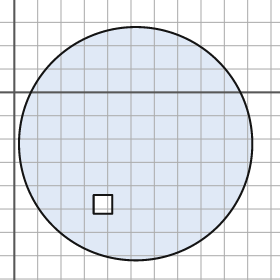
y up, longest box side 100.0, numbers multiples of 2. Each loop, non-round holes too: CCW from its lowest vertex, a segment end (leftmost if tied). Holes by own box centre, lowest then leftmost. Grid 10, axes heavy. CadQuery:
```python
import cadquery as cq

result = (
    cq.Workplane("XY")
    .moveTo(52.0, -22.0)
    .circle(50.0)
    .moveTo(34.0, -52.0)
    .lineTo(42.0, -52.0)
    .lineTo(42.0, -44.0)
    .lineTo(34.0, -44.0)
    .close()
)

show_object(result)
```